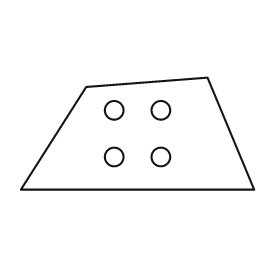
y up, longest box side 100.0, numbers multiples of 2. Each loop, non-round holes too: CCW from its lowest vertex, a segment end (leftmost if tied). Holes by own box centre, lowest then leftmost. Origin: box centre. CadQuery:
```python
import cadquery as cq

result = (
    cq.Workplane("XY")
    .moveTo(-50.0, -24.0)
    .lineTo(50.0, -24.0)
    .lineTo(30.0, 24.0)
    .lineTo(-22.0, 20.0)
    .close()
    .moveTo(-10.0, -10.0)
    .circle(4.0)
    .moveTo(10.0, -10.0)
    .circle(4.0)
    .moveTo(-10.0, 10.0)
    .circle(4.0)
    .moveTo(10.0, 10.0)
    .circle(4.0)
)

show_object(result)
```